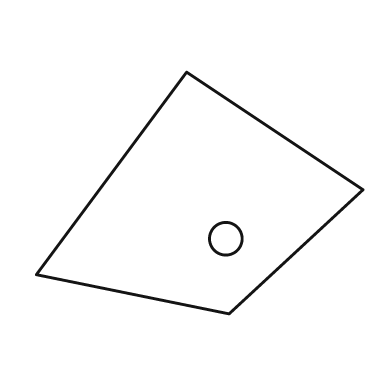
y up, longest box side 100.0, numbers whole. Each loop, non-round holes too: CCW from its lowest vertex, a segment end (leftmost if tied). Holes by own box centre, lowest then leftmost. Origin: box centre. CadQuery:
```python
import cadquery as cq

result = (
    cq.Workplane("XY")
    .moveTo(9.0, -37.0)
    .lineTo(50.0, 1.0)
    .lineTo(-4.0, 37.0)
    .lineTo(-50.0, -25.0)
    .close()
    .moveTo(8.0, -14.0)
    .circle(5.0)
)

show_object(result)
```